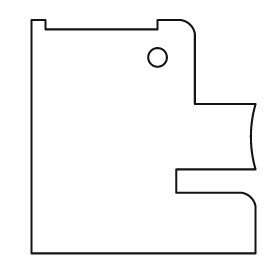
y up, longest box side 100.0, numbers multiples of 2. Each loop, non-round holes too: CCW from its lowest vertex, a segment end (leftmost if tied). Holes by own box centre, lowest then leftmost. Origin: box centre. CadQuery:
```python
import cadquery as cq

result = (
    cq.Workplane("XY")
    .moveTo(-48.0, -50.0)
    .lineTo(48.0, -50.0)
    .lineTo(48.0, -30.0)
    .threePointArc((46.0, -26.0), (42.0, -24.0))
    .lineTo(14.0, -24.0)
    .lineTo(14.0, -14.0)
    .lineTo(48.0, -14.0)
    .threePointArc((46.0, 0.0), (48.0, 14.0))
    .lineTo(22.0, 14.0)
    .lineTo(22.0, 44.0)
    .threePointArc((20.0, 48.0), (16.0, 50.0))
    .lineTo(6.0, 50.0)
    .lineTo(6.0, 46.0)
    .lineTo(-42.0, 46.0)
    .lineTo(-42.0, 50.0)
    .lineTo(-48.0, 50.0)
    .close()
    .moveTo(6.0, 34.0)
    .circle(4.0)
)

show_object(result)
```